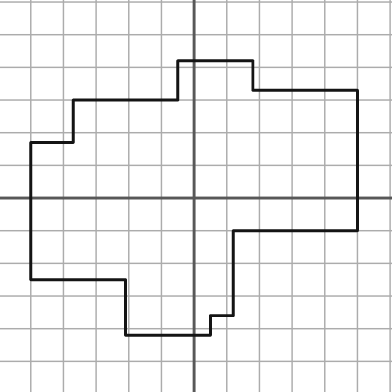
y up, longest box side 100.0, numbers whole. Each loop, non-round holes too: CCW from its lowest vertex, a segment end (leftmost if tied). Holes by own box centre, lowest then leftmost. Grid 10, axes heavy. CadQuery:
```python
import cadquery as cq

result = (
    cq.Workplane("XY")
    .moveTo(-21.0, -42.0)
    .lineTo(5.0, -42.0)
    .lineTo(5.0, -36.0)
    .lineTo(12.0, -36.0)
    .lineTo(12.0, -10.0)
    .lineTo(50.0, -10.0)
    .lineTo(50.0, 33.0)
    .lineTo(18.0, 33.0)
    .lineTo(18.0, 42.0)
    .lineTo(-5.0, 42.0)
    .lineTo(-5.0, 30.0)
    .lineTo(-37.0, 30.0)
    .lineTo(-37.0, 17.0)
    .lineTo(-50.0, 17.0)
    .lineTo(-50.0, -25.0)
    .lineTo(-21.0, -25.0)
    .close()
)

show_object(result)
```